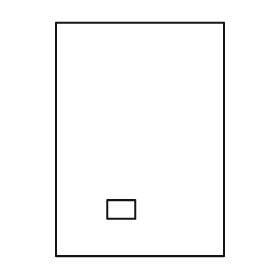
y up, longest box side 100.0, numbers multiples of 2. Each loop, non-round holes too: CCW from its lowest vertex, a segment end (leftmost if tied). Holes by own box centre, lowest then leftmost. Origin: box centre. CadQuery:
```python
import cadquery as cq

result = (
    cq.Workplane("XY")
    .moveTo(-36.0, -50.0)
    .lineTo(36.0, -50.0)
    .lineTo(36.0, 50.0)
    .lineTo(-36.0, 50.0)
    .close()
    .moveTo(-14.0, -34.0)
    .lineTo(-2.0, -34.0)
    .lineTo(-2.0, -26.0)
    .lineTo(-14.0, -26.0)
    .close()
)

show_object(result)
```